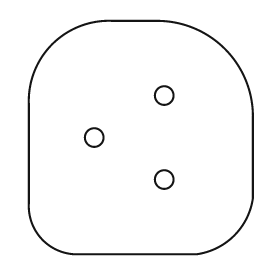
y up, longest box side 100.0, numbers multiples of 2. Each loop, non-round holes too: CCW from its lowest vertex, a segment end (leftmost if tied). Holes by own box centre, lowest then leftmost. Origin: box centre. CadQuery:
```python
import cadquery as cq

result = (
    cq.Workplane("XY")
    .moveTo(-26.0, -50.0)
    .lineTo(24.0, -50.0)
    .threePointArc((40.0, -42.0), (48.0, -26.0))
    .lineTo(48.0, 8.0)
    .threePointArc((36.0, 38.0), (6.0, 50.0))
    .lineTo(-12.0, 50.0)
    .threePointArc((-38.0, 40.0), (-48.0, 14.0))
    .lineTo(-48.0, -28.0)
    .threePointArc((-42.0, -44.0), (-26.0, -50.0))
    .close()
    .moveTo(10.0, -18.0)
    .circle(4.0)
    .moveTo(-20.0, 0.0)
    .circle(4.0)
    .moveTo(10.0, 18.0)
    .circle(4.0)
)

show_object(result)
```